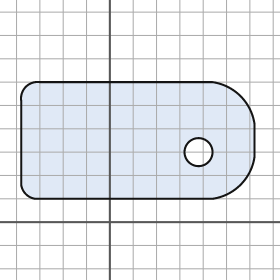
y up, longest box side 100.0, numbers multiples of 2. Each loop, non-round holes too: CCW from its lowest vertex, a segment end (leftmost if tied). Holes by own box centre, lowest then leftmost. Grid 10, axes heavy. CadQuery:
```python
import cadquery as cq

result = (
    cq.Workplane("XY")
    .moveTo(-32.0, 10.0)
    .lineTo(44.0, 10.0)
    .threePointArc((56.0, 16.0), (62.0, 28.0))
    .lineTo(62.0, 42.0)
    .threePointArc((56.0, 54.0), (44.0, 60.0))
    .lineTo(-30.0, 60.0)
    .threePointArc((-36.0, 58.0), (-38.0, 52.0))
    .lineTo(-38.0, 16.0)
    .threePointArc((-36.0, 12.0), (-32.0, 10.0))
    .close()
    .moveTo(38.0, 30.0)
    .circle(6.0)
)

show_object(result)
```